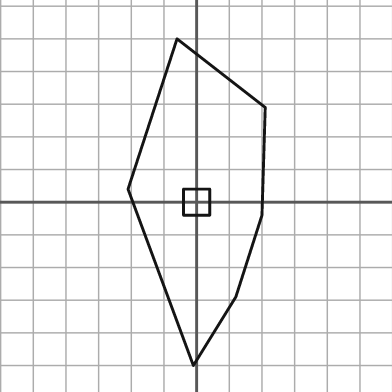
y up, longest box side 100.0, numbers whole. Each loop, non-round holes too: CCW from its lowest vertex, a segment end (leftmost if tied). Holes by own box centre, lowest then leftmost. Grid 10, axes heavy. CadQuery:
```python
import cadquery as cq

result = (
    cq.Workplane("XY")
    .moveTo(-1.0, -50.0)
    .lineTo(12.0, -29.0)
    .lineTo(20.0, -4.0)
    .lineTo(21.0, 29.0)
    .lineTo(-6.0, 50.0)
    .lineTo(-21.0, 4.0)
    .close()
    .moveTo(-4.0, -4.0)
    .lineTo(4.0, -4.0)
    .lineTo(4.0, 4.0)
    .lineTo(-4.0, 4.0)
    .close()
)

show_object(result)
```